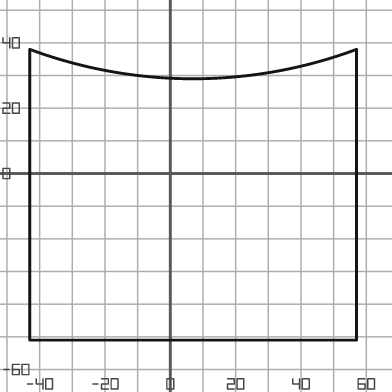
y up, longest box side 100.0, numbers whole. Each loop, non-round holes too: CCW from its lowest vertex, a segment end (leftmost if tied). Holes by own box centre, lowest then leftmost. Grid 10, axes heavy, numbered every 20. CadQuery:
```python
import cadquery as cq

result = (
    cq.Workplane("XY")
    .moveTo(-43.0, -51.0)
    .lineTo(57.0, -51.0)
    .lineTo(57.0, 38.0)
    .threePointArc((7.0, 29.0), (-43.0, 38.0))
    .close()
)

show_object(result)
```